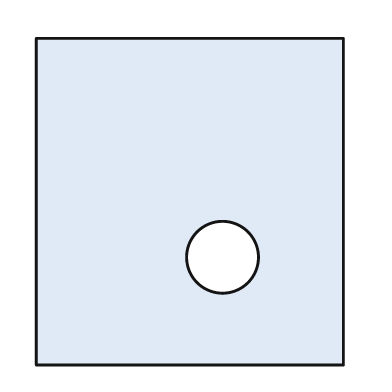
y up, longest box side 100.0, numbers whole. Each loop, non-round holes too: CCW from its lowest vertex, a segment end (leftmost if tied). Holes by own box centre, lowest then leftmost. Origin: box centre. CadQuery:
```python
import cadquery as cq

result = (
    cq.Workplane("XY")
    .moveTo(-47.0, -50.0)
    .lineTo(47.0, -50.0)
    .lineTo(47.0, 50.0)
    .lineTo(-47.0, 50.0)
    .close()
    .moveTo(10.0, -17.0)
    .circle(11.0)
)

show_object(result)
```